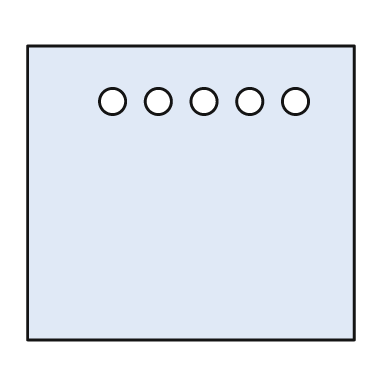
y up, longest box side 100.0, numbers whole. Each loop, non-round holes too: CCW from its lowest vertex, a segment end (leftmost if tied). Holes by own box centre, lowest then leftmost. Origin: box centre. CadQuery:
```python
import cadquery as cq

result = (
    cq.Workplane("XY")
    .moveTo(-50.0, -45.0)
    .lineTo(50.0, -45.0)
    .lineTo(50.0, 45.0)
    .lineTo(-50.0, 45.0)
    .close()
    .moveTo(-24.0, 28.0)
    .circle(4.0)
    .moveTo(-10.0, 28.0)
    .circle(4.0)
    .moveTo(4.0, 28.0)
    .circle(4.0)
    .moveTo(18.0, 28.0)
    .circle(4.0)
    .moveTo(32.0, 28.0)
    .circle(4.0)
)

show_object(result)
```